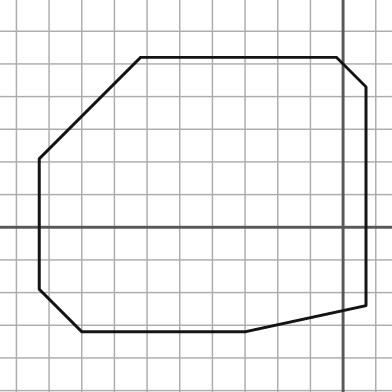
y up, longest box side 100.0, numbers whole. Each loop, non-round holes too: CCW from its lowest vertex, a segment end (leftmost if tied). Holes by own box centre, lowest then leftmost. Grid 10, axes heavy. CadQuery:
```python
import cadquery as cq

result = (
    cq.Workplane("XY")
    .moveTo(-80.0, -32.0)
    .lineTo(-30.0, -32.0)
    .lineTo(7.0, -24.0)
    .lineTo(7.0, 43.0)
    .lineTo(-2.0, 52.0)
    .lineTo(-62.0, 52.0)
    .lineTo(-93.0, 21.0)
    .lineTo(-93.0, -19.0)
    .close()
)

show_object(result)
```